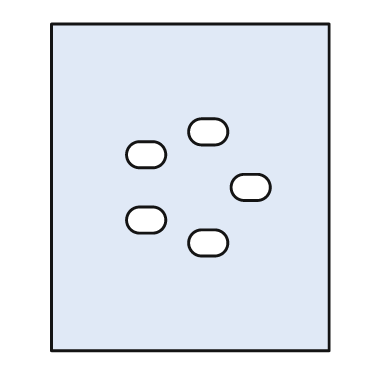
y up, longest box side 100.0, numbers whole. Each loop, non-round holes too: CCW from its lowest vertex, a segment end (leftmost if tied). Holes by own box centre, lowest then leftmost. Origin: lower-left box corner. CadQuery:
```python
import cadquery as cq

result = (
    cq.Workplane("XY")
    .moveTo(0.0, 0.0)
    .lineTo(85.0, 0.0)
    .lineTo(85.0, 100.0)
    .lineTo(0.0, 100.0)
    .close()
    .moveTo(46.0, 29.0)
    .lineTo(50.0, 29.0)
    .threePointArc((54.0, 33.0), (50.0, 37.0))
    .lineTo(46.0, 37.0)
    .threePointArc((42.0, 33.0), (46.0, 29.0))
    .close()
    .moveTo(27.0, 36.0)
    .lineTo(31.0, 36.0)
    .threePointArc((35.0, 40.0), (31.0, 44.0))
    .lineTo(27.0, 44.0)
    .threePointArc((23.0, 40.0), (27.0, 36.0))
    .close()
    .moveTo(59.0, 46.0)
    .lineTo(63.0, 46.0)
    .threePointArc((67.0, 50.0), (63.0, 54.0))
    .lineTo(59.0, 54.0)
    .threePointArc((55.0, 50.0), (59.0, 46.0))
    .close()
    .moveTo(27.0, 56.0)
    .lineTo(31.0, 56.0)
    .threePointArc((35.0, 60.0), (31.0, 64.0))
    .lineTo(27.0, 64.0)
    .threePointArc((23.0, 60.0), (27.0, 56.0))
    .close()
    .moveTo(46.0, 63.0)
    .lineTo(50.0, 63.0)
    .threePointArc((54.0, 67.0), (50.0, 71.0))
    .lineTo(46.0, 71.0)
    .threePointArc((42.0, 67.0), (46.0, 63.0))
    .close()
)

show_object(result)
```